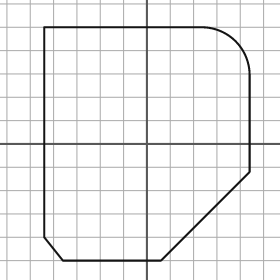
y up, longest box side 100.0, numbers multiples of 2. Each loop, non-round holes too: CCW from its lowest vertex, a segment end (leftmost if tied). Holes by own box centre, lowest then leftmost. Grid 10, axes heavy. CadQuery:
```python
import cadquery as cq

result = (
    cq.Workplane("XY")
    .moveTo(-36.0, -50.0)
    .lineTo(6.0, -50.0)
    .lineTo(44.0, -12.0)
    .lineTo(44.0, 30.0)
    .threePointArc((38.0, 44.0), (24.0, 50.0))
    .lineTo(-44.0, 50.0)
    .lineTo(-44.0, -40.0)
    .close()
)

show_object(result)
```